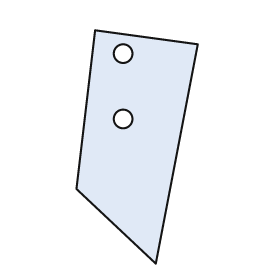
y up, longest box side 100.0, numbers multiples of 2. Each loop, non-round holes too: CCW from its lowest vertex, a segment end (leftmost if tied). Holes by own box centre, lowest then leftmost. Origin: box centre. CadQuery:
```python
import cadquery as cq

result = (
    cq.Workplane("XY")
    .moveTo(8.0, -50.0)
    .lineTo(26.0, 44.0)
    .lineTo(-18.0, 50.0)
    .lineTo(-26.0, -18.0)
    .close()
    .moveTo(-6.0, 12.0)
    .circle(4.0)
    .moveTo(-6.0, 40.0)
    .circle(4.0)
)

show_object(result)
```